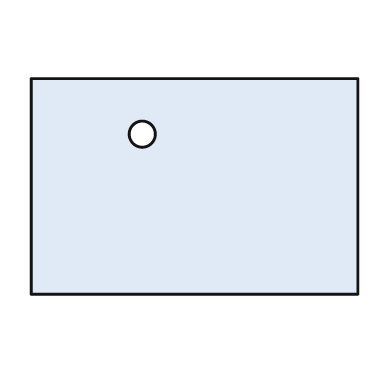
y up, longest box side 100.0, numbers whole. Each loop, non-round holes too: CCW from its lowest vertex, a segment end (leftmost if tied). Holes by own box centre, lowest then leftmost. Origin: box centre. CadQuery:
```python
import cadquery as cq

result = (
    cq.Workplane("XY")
    .moveTo(-50.0, -33.0)
    .lineTo(50.0, -33.0)
    .lineTo(50.0, 33.0)
    .lineTo(-50.0, 33.0)
    .close()
    .moveTo(-16.0, 16.0)
    .circle(4.0)
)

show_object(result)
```